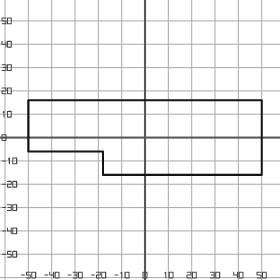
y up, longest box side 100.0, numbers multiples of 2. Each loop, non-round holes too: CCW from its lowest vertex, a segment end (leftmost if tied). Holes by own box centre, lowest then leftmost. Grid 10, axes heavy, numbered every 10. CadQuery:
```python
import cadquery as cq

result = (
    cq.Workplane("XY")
    .moveTo(-18.0, -16.0)
    .lineTo(50.0, -16.0)
    .lineTo(50.0, 16.0)
    .lineTo(-50.0, 16.0)
    .lineTo(-50.0, -6.0)
    .lineTo(-18.0, -6.0)
    .close()
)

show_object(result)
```